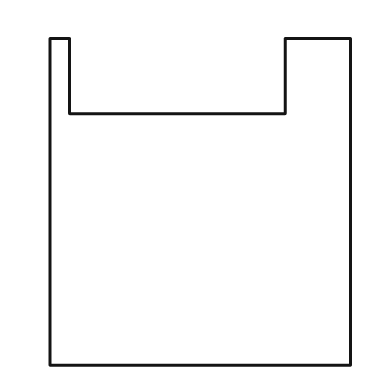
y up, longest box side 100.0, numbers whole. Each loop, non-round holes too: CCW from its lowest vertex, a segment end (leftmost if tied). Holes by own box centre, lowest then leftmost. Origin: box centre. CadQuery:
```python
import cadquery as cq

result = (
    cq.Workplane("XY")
    .moveTo(-46.0, -50.0)
    .lineTo(46.0, -50.0)
    .lineTo(46.0, 50.0)
    .lineTo(26.0, 50.0)
    .lineTo(26.0, 27.0)
    .lineTo(-40.0, 27.0)
    .lineTo(-40.0, 50.0)
    .lineTo(-46.0, 50.0)
    .close()
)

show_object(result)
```